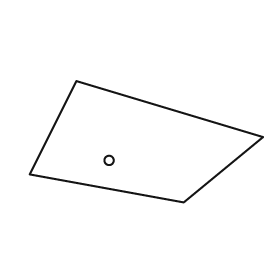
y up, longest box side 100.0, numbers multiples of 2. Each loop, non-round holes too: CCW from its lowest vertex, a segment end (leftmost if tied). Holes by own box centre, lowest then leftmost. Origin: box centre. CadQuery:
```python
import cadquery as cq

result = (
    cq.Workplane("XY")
    .moveTo(16.0, -26.0)
    .lineTo(50.0, 2.0)
    .lineTo(-30.0, 26.0)
    .lineTo(-50.0, -14.0)
    .close()
    .moveTo(-16.0, -8.0)
    .circle(2.0)
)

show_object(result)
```